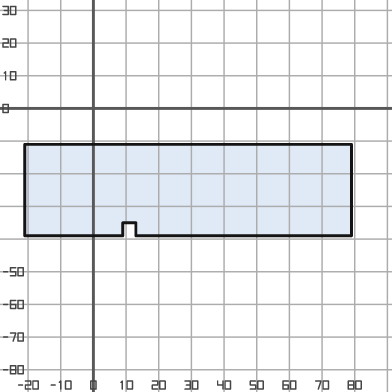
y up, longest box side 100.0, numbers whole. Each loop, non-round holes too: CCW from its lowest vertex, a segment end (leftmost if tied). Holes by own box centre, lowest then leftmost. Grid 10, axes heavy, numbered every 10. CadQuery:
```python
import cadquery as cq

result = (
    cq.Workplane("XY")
    .moveTo(-21.0, -39.0)
    .lineTo(9.0, -39.0)
    .lineTo(9.0, -35.0)
    .lineTo(13.0, -35.0)
    .lineTo(13.0, -39.0)
    .lineTo(79.0, -39.0)
    .lineTo(79.0, -11.0)
    .lineTo(-21.0, -11.0)
    .close()
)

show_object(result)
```